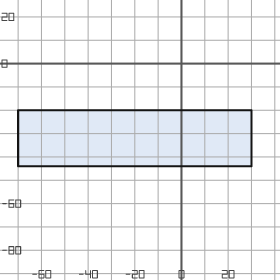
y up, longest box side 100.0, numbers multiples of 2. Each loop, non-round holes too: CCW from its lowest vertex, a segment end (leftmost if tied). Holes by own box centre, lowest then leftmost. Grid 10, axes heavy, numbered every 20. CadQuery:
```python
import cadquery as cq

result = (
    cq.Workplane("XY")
    .moveTo(-70.0, -44.0)
    .lineTo(30.0, -44.0)
    .lineTo(30.0, -20.0)
    .lineTo(-70.0, -20.0)
    .close()
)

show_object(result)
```